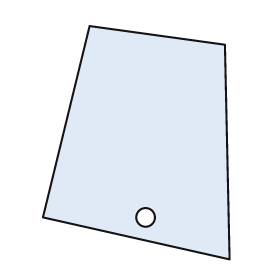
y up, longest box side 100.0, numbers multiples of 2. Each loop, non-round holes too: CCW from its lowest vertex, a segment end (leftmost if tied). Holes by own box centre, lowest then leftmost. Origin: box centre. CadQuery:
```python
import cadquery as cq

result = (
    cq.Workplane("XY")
    .moveTo(40.0, -50.0)
    .lineTo(38.0, 42.0)
    .lineTo(-20.0, 50.0)
    .lineTo(-40.0, -32.0)
    .close()
    .moveTo(4.0, -32.0)
    .circle(4.0)
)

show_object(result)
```